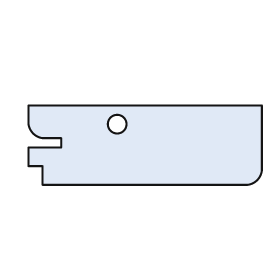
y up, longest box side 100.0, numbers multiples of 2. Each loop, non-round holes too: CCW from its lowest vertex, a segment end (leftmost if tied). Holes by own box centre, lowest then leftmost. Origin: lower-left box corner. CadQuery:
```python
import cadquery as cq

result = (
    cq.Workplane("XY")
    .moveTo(6.0, 0.0)
    .lineTo(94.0, 0.0)
    .threePointArc((98.0, 2.0), (100.0, 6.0))
    .lineTo(100.0, 34.0)
    .lineTo(0.0, 34.0)
    .lineTo(0.0, 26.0)
    .threePointArc((2.0, 22.0), (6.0, 20.0))
    .lineTo(14.0, 20.0)
    .lineTo(14.0, 16.0)
    .lineTo(0.0, 16.0)
    .lineTo(0.0, 8.0)
    .lineTo(6.0, 8.0)
    .close()
    .moveTo(38.0, 26.0)
    .circle(4.0)
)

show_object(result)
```